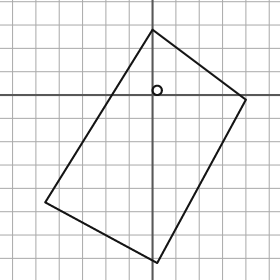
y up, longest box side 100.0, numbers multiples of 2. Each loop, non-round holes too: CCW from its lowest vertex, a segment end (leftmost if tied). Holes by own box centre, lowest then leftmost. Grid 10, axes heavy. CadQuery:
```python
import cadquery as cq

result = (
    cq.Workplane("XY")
    .moveTo(2.0, -72.0)
    .lineTo(40.0, -2.0)
    .lineTo(0.0, 28.0)
    .lineTo(-46.0, -46.0)
    .close()
    .moveTo(2.0, 2.0)
    .circle(2.0)
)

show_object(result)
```